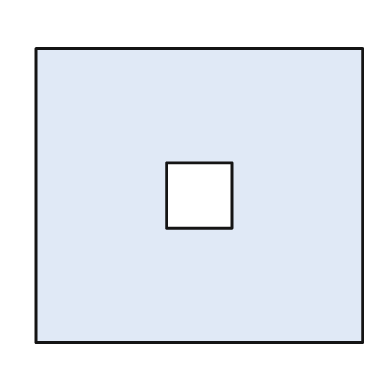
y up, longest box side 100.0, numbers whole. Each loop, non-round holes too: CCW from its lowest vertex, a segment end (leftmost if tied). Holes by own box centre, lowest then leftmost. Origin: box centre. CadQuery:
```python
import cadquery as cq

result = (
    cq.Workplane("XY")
    .moveTo(-50.0, -45.0)
    .lineTo(50.0, -45.0)
    .lineTo(50.0, 45.0)
    .lineTo(-50.0, 45.0)
    .close()
    .moveTo(-10.0, -10.0)
    .lineTo(10.0, -10.0)
    .lineTo(10.0, 10.0)
    .lineTo(-10.0, 10.0)
    .close()
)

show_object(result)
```